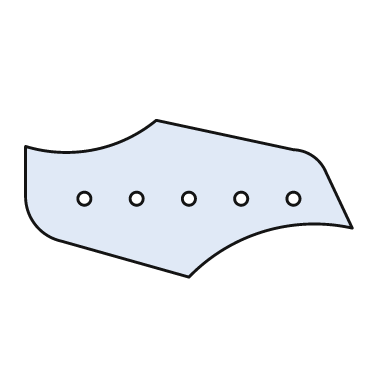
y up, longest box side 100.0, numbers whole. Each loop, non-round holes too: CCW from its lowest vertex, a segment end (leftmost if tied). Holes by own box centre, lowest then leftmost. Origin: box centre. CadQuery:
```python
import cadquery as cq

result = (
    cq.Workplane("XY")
    .moveTo(0.0, -24.0)
    .threePointArc((23.0, -10.0), (50.0, -9.0))
    .lineTo(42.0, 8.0)
    .threePointArc((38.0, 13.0), (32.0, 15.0))
    .lineTo(-10.0, 24.0)
    .threePointArc((-29.0, 15.0), (-50.0, 16.0))
    .lineTo(-50.0, 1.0)
    .threePointArc((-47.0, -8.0), (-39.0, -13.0))
    .close()
    .moveTo(-32.0, 0.0)
    .circle(2.0)
    .moveTo(-16.0, 0.0)
    .circle(2.0)
    .moveTo(0.0, 0.0)
    .circle(2.0)
    .moveTo(16.0, 0.0)
    .circle(2.0)
    .moveTo(32.0, 0.0)
    .circle(2.0)
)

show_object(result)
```